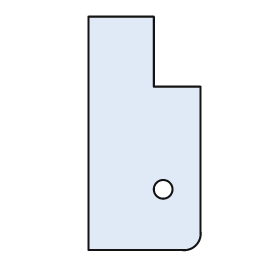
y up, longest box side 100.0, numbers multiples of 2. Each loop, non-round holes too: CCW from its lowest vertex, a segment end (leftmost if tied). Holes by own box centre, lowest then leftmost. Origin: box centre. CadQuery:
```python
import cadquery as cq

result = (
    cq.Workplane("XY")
    .moveTo(-24.0, -50.0)
    .lineTo(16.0, -50.0)
    .threePointArc((22.0, -48.0), (24.0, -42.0))
    .lineTo(24.0, 20.0)
    .lineTo(4.0, 20.0)
    .lineTo(4.0, 50.0)
    .lineTo(-24.0, 50.0)
    .close()
    .moveTo(8.0, -24.0)
    .circle(4.0)
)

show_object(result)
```